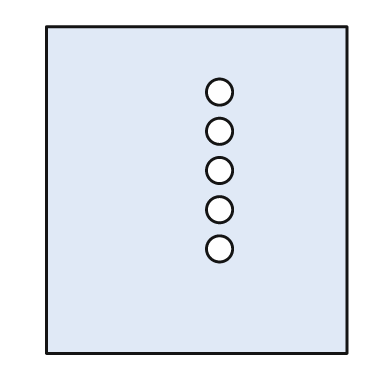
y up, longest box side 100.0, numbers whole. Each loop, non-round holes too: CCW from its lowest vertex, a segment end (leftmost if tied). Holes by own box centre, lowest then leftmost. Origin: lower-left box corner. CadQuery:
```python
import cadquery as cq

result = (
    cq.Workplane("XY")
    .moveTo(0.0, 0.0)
    .lineTo(92.0, 0.0)
    .lineTo(92.0, 100.0)
    .lineTo(0.0, 100.0)
    .close()
    .moveTo(53.0, 32.0)
    .circle(4.0)
    .moveTo(53.0, 44.0)
    .circle(4.0)
    .moveTo(53.0, 56.0)
    .circle(4.0)
    .moveTo(53.0, 68.0)
    .circle(4.0)
    .moveTo(53.0, 80.0)
    .circle(4.0)
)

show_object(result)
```